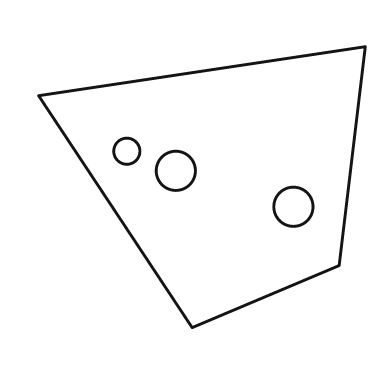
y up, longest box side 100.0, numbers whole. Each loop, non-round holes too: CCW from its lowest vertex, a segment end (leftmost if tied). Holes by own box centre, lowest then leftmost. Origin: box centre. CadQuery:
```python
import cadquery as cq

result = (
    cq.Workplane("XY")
    .moveTo(-3.0, -43.0)
    .lineTo(42.0, -24.0)
    .lineTo(50.0, 43.0)
    .lineTo(-50.0, 28.0)
    .close()
    .moveTo(28.0, -6.0)
    .circle(6.0)
    .moveTo(-8.0, 5.0)
    .circle(6.0)
    .moveTo(-23.0, 11.0)
    .circle(4.0)
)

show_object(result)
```